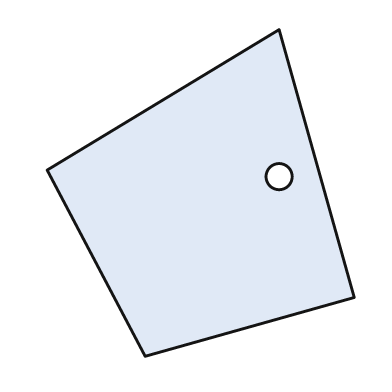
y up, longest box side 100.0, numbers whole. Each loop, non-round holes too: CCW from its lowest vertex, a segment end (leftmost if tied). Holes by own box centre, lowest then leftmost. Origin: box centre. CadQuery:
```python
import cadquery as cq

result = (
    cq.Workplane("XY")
    .moveTo(-17.0, -50.0)
    .lineTo(47.0, -32.0)
    .lineTo(24.0, 50.0)
    .lineTo(-47.0, 7.0)
    .close()
    .moveTo(24.0, 5.0)
    .circle(4.0)
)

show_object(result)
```